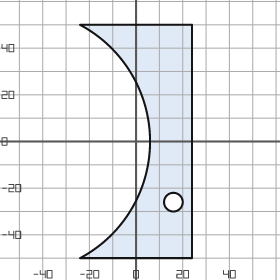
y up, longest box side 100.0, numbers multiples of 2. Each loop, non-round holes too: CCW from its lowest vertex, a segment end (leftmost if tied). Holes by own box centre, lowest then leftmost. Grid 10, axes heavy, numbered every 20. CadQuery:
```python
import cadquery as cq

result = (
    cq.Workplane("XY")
    .moveTo(-24.0, -50.0)
    .lineTo(24.0, -50.0)
    .lineTo(24.0, 50.0)
    .lineTo(-24.0, 50.0)
    .threePointArc((6.0, 0.0), (-24.0, -50.0))
    .close()
    .moveTo(16.0, -26.0)
    .circle(4.0)
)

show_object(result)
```